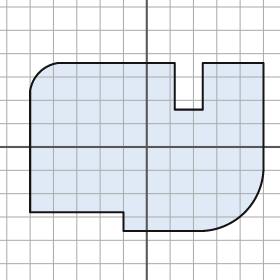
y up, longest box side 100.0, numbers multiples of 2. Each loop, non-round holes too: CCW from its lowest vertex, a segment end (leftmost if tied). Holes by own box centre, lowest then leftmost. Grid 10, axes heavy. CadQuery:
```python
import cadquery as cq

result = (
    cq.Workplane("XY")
    .moveTo(-10.0, -36.0)
    .lineTo(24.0, -36.0)
    .threePointArc((42.0, -28.0), (50.0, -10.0))
    .lineTo(50.0, 36.0)
    .lineTo(24.0, 36.0)
    .lineTo(24.0, 16.0)
    .lineTo(12.0, 16.0)
    .lineTo(12.0, 36.0)
    .lineTo(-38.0, 36.0)
    .threePointArc((-46.0, 32.0), (-50.0, 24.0))
    .lineTo(-50.0, -28.0)
    .lineTo(-10.0, -28.0)
    .close()
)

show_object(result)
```